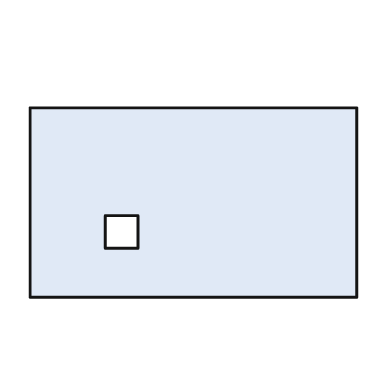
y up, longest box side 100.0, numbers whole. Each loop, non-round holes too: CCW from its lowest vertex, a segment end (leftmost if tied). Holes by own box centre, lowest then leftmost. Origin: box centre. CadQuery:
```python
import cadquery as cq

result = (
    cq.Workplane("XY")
    .moveTo(-50.0, -29.0)
    .lineTo(50.0, -29.0)
    .lineTo(50.0, 29.0)
    .lineTo(-50.0, 29.0)
    .close()
    .moveTo(-27.0, -14.0)
    .lineTo(-17.0, -14.0)
    .lineTo(-17.0, -4.0)
    .lineTo(-27.0, -4.0)
    .close()
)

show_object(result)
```